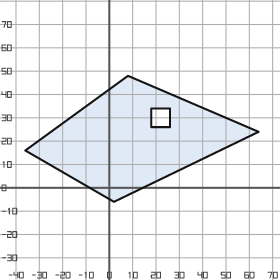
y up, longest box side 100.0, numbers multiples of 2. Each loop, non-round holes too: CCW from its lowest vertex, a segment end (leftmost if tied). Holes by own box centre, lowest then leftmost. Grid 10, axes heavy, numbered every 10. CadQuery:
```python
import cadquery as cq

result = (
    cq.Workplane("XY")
    .moveTo(2.0, -6.0)
    .lineTo(64.0, 24.0)
    .lineTo(8.0, 48.0)
    .lineTo(-36.0, 16.0)
    .close()
    .moveTo(18.0, 26.0)
    .lineTo(26.0, 26.0)
    .lineTo(26.0, 34.0)
    .lineTo(18.0, 34.0)
    .close()
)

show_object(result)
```